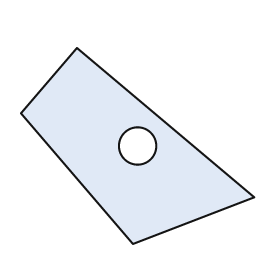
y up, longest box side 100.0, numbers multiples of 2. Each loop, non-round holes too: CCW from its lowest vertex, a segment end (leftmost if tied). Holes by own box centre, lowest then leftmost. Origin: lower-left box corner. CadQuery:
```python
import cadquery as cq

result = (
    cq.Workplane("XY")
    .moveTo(48.0, 0.0)
    .lineTo(100.0, 20.0)
    .lineTo(24.0, 84.0)
    .lineTo(0.0, 56.0)
    .close()
    .moveTo(50.0, 42.0)
    .circle(8.0)
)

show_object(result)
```